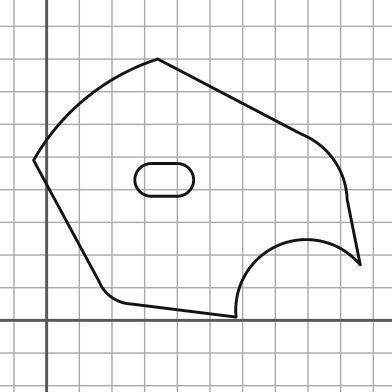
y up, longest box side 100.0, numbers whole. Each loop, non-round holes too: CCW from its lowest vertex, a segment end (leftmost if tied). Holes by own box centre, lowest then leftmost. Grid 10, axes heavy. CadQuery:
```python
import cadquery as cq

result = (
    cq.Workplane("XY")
    .moveTo(58.0, 1.0)
    .threePointArc((71.0, 23.0), (96.0, 17.0))
    .lineTo(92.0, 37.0)
    .threePointArc((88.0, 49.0), (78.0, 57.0))
    .lineTo(34.0, 80.0)
    .threePointArc((12.0, 68.0), (-4.0, 49.0))
    .lineTo(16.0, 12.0)
    .threePointArc((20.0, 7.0), (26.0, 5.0))
    .close()
    .moveTo(32.0, 38.0)
    .lineTo(40.0, 38.0)
    .threePointArc((45.0, 43.0), (40.0, 48.0))
    .lineTo(32.0, 48.0)
    .threePointArc((27.0, 43.0), (32.0, 38.0))
    .close()
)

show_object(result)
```